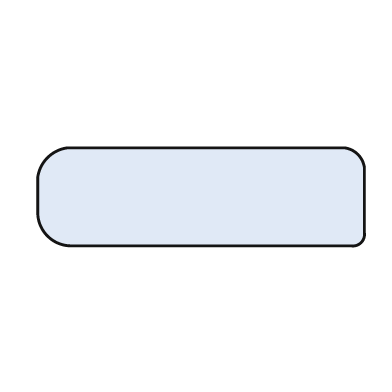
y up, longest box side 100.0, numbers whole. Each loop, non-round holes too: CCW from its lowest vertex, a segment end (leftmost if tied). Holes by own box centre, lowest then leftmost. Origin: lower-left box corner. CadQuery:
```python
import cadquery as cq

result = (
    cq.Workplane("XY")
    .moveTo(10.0, 0.0)
    .lineTo(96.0, 0.0)
    .threePointArc((99.0, 1.0), (100.0, 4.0))
    .lineTo(100.0, 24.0)
    .threePointArc((98.0, 28.0), (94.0, 30.0))
    .lineTo(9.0, 30.0)
    .threePointArc((3.0, 27.0), (0.0, 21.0))
    .lineTo(0.0, 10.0)
    .threePointArc((3.0, 3.0), (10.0, 0.0))
    .close()
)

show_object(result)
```